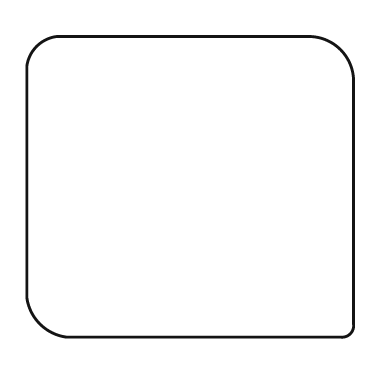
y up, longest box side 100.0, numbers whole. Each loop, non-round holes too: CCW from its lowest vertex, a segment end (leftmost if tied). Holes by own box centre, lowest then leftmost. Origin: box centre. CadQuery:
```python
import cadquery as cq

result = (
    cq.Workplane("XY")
    .moveTo(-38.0, -46.0)
    .lineTo(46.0, -46.0)
    .threePointArc((49.0, -45.0), (50.0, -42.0))
    .lineTo(50.0, 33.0)
    .threePointArc((46.0, 42.0), (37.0, 46.0))
    .lineTo(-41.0, 46.0)
    .threePointArc((-47.0, 43.0), (-50.0, 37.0))
    .lineTo(-50.0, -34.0)
    .threePointArc((-46.0, -42.0), (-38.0, -46.0))
    .close()
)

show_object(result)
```